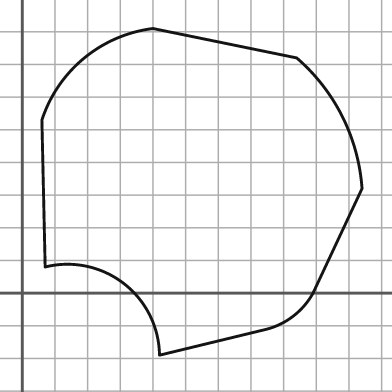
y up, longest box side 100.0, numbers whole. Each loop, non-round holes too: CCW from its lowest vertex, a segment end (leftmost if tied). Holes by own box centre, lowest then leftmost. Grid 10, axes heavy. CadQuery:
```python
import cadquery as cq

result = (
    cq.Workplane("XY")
    .moveTo(42.0, -19.0)
    .lineTo(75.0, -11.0)
    .threePointArc((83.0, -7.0), (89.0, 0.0))
    .lineTo(104.0, 32.0)
    .threePointArc((98.0, 54.0), (84.0, 72.0))
    .lineTo(40.0, 81.0)
    .threePointArc((19.0, 72.0), (6.0, 53.0))
    .lineTo(7.0, 8.0)
    .threePointArc((31.0, 3.0), (42.0, -19.0))
    .close()
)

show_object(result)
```